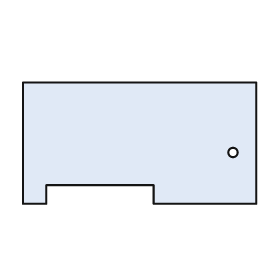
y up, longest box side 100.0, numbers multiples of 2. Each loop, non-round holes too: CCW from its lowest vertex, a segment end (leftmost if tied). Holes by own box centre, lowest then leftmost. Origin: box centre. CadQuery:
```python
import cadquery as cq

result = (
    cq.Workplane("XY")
    .moveTo(-50.0, -26.0)
    .lineTo(-40.0, -26.0)
    .lineTo(-40.0, -18.0)
    .lineTo(6.0, -18.0)
    .lineTo(6.0, -26.0)
    .lineTo(50.0, -26.0)
    .lineTo(50.0, 26.0)
    .lineTo(-50.0, 26.0)
    .close()
    .moveTo(40.0, -4.0)
    .circle(2.0)
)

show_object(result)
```